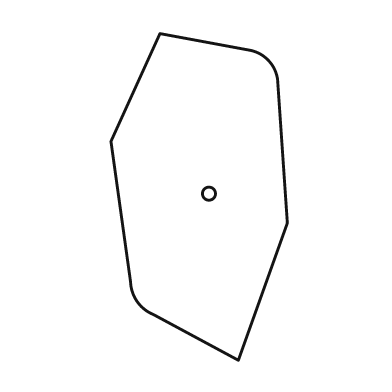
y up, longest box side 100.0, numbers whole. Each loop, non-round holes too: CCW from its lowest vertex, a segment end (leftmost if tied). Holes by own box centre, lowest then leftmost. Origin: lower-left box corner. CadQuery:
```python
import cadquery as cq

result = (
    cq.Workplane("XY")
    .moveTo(39.0, 0.0)
    .lineTo(54.0, 42.0)
    .lineTo(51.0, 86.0)
    .threePointArc((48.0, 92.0), (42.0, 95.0))
    .lineTo(15.0, 100.0)
    .lineTo(0.0, 67.0)
    .lineTo(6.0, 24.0)
    .threePointArc((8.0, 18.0), (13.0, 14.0))
    .close()
    .moveTo(30.0, 51.0)
    .circle(2.0)
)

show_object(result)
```